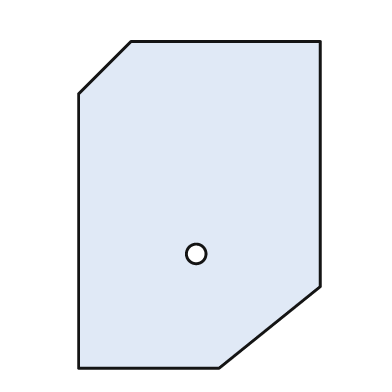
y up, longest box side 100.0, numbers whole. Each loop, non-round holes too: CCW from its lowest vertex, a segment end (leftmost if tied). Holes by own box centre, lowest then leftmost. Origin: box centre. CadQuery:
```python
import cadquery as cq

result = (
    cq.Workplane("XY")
    .moveTo(-37.0, -50.0)
    .lineTo(6.0, -50.0)
    .lineTo(37.0, -25.0)
    .lineTo(37.0, 50.0)
    .lineTo(-21.0, 50.0)
    .lineTo(-37.0, 34.0)
    .close()
    .moveTo(-1.0, -15.0)
    .circle(3.0)
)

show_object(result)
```